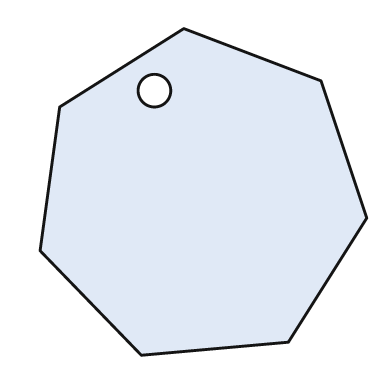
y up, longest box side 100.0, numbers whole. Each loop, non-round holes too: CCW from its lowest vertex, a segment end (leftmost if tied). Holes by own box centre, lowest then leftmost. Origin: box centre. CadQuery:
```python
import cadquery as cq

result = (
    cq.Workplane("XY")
    .moveTo(-19.0, -50.0)
    .lineTo(26.0, -46.0)
    .lineTo(50.0, -8.0)
    .lineTo(36.0, 34.0)
    .lineTo(-6.0, 50.0)
    .lineTo(-44.0, 26.0)
    .lineTo(-50.0, -18.0)
    .close()
    .moveTo(-15.0, 31.0)
    .circle(5.0)
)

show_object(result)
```